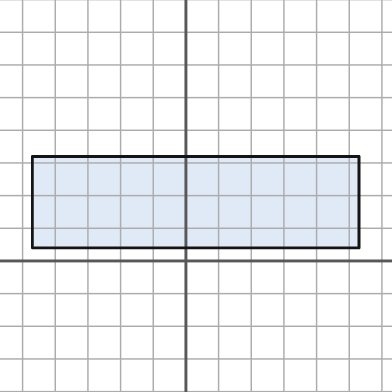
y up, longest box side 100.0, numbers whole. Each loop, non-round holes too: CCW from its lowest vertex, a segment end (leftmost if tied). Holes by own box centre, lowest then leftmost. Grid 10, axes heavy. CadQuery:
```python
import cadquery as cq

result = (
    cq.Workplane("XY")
    .moveTo(-47.0, 4.0)
    .lineTo(53.0, 4.0)
    .lineTo(53.0, 32.0)
    .lineTo(-47.0, 32.0)
    .close()
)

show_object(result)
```